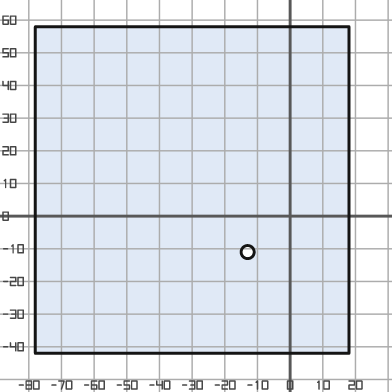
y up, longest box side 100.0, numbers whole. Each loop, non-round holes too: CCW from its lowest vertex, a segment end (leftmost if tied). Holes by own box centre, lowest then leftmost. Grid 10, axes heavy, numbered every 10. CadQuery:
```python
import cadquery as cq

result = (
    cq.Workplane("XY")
    .moveTo(-78.0, -42.0)
    .lineTo(18.0, -42.0)
    .lineTo(18.0, 58.0)
    .lineTo(-78.0, 58.0)
    .close()
    .moveTo(-13.0, -11.0)
    .circle(2.0)
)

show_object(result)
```